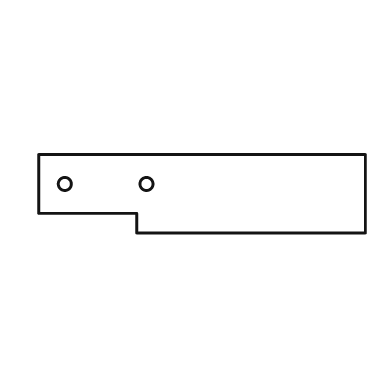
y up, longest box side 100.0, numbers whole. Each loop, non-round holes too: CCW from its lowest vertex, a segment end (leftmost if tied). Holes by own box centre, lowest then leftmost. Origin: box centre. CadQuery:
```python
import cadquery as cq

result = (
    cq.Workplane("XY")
    .moveTo(-20.0, -12.0)
    .lineTo(50.0, -12.0)
    .lineTo(50.0, 12.0)
    .lineTo(-50.0, 12.0)
    .lineTo(-50.0, -6.0)
    .lineTo(-20.0, -6.0)
    .close()
    .moveTo(-42.0, 3.0)
    .circle(2.0)
    .moveTo(-17.0, 3.0)
    .circle(2.0)
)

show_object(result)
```